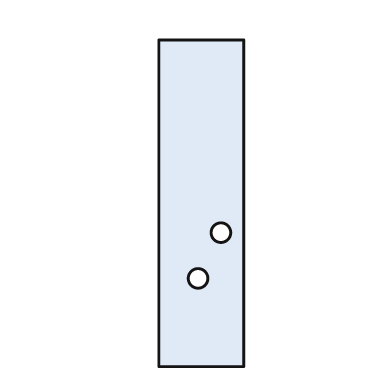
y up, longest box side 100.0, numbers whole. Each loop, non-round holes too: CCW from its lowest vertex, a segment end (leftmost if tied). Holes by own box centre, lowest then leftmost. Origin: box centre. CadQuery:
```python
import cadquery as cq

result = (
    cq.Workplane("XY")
    .moveTo(-13.0, -50.0)
    .lineTo(13.0, -50.0)
    .lineTo(13.0, 50.0)
    .lineTo(-13.0, 50.0)
    .close()
    .moveTo(-1.0, -23.0)
    .circle(3.0)
    .moveTo(6.0, -9.0)
    .circle(3.0)
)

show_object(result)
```